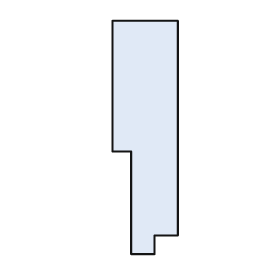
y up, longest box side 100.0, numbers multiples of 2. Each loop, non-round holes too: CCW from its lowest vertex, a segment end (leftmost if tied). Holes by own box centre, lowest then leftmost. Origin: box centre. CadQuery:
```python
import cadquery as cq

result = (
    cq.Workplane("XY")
    .moveTo(-6.0, -50.0)
    .lineTo(4.0, -50.0)
    .lineTo(4.0, -42.0)
    .lineTo(14.0, -42.0)
    .lineTo(14.0, 50.0)
    .lineTo(-14.0, 50.0)
    .lineTo(-14.0, -6.0)
    .lineTo(-6.0, -6.0)
    .close()
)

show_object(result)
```